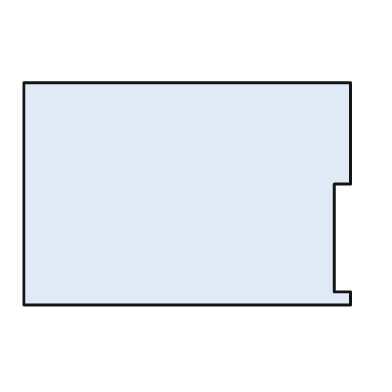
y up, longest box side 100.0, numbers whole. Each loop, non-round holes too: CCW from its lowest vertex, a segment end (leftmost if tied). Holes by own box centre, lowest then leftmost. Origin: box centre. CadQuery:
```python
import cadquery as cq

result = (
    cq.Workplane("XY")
    .moveTo(-50.0, -34.0)
    .lineTo(50.0, -34.0)
    .lineTo(50.0, -30.0)
    .lineTo(45.0, -30.0)
    .lineTo(45.0, 3.0)
    .lineTo(50.0, 3.0)
    .lineTo(50.0, 34.0)
    .lineTo(-50.0, 34.0)
    .close()
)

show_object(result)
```